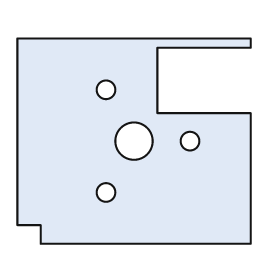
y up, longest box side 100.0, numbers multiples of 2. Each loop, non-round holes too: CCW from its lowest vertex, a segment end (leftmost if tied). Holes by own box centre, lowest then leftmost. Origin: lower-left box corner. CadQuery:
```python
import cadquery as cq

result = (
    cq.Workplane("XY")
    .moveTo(10.0, 0.0)
    .lineTo(100.0, 0.0)
    .lineTo(100.0, 56.0)
    .lineTo(60.0, 56.0)
    .lineTo(60.0, 84.0)
    .lineTo(100.0, 84.0)
    .lineTo(100.0, 88.0)
    .lineTo(0.0, 88.0)
    .lineTo(0.0, 8.0)
    .lineTo(10.0, 8.0)
    .close()
    .moveTo(38.0, 22.0)
    .circle(4.0)
    .moveTo(50.0, 44.0)
    .circle(8.0)
    .moveTo(74.0, 44.0)
    .circle(4.0)
    .moveTo(38.0, 66.0)
    .circle(4.0)
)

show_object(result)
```